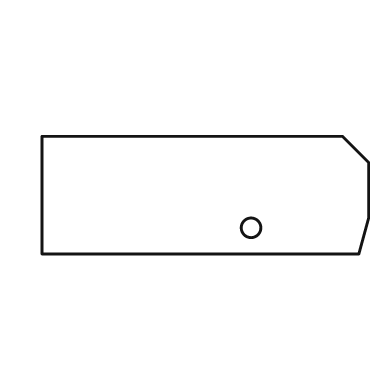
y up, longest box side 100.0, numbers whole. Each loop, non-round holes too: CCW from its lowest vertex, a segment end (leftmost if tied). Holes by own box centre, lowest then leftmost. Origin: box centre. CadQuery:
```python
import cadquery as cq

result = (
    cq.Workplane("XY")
    .moveTo(-50.0, -18.0)
    .lineTo(47.0, -18.0)
    .lineTo(50.0, -7.0)
    .lineTo(50.0, 10.0)
    .lineTo(42.0, 18.0)
    .lineTo(-50.0, 18.0)
    .close()
    .moveTo(14.0, -10.0)
    .circle(3.0)
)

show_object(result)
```